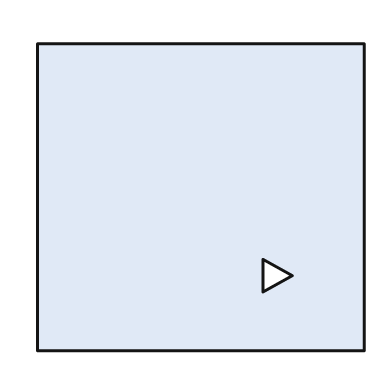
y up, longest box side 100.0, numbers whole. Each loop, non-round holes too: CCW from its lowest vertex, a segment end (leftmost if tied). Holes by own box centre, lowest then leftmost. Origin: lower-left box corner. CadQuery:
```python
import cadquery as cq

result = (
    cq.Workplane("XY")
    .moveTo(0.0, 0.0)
    .lineTo(100.0, 0.0)
    .lineTo(100.0, 94.0)
    .lineTo(0.0, 94.0)
    .close()
    .moveTo(69.0, 18.0)
    .lineTo(78.0, 23.0)
    .lineTo(69.0, 28.0)
    .close()
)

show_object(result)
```